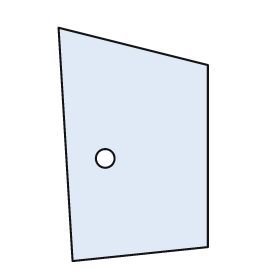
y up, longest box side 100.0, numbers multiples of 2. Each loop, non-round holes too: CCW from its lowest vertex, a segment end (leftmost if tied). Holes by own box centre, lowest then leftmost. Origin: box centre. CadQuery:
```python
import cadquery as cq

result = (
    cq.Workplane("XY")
    .moveTo(-26.0, -50.0)
    .lineTo(32.0, -44.0)
    .lineTo(32.0, 34.0)
    .lineTo(-32.0, 50.0)
    .close()
    .moveTo(-12.0, -6.0)
    .circle(4.0)
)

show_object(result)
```